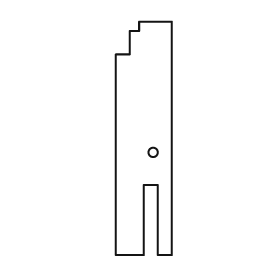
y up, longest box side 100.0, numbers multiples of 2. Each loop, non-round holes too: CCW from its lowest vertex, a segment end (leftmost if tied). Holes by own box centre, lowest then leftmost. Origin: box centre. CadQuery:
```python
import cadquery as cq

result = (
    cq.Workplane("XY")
    .moveTo(-12.0, -50.0)
    .lineTo(0.0, -50.0)
    .lineTo(0.0, -20.0)
    .lineTo(6.0, -20.0)
    .lineTo(6.0, -50.0)
    .lineTo(12.0, -50.0)
    .lineTo(12.0, 50.0)
    .lineTo(-2.0, 50.0)
    .lineTo(-2.0, 46.0)
    .lineTo(-6.0, 46.0)
    .lineTo(-6.0, 36.0)
    .lineTo(-12.0, 36.0)
    .close()
    .moveTo(4.0, -6.0)
    .circle(2.0)
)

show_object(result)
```